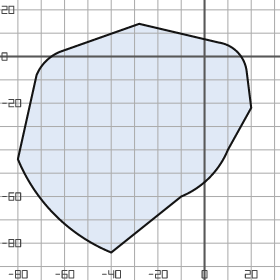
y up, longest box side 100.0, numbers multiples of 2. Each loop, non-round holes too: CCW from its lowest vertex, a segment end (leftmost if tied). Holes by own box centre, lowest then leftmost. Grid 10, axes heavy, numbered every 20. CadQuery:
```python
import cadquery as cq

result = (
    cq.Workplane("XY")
    .moveTo(-40.0, -84.0)
    .lineTo(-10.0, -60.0)
    .threePointArc((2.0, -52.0), (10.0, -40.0))
    .lineTo(20.0, -22.0)
    .lineTo(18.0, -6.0)
    .threePointArc((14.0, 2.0), (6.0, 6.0))
    .lineTo(-28.0, 14.0)
    .lineTo(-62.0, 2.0)
    .threePointArc((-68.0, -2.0), (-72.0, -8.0))
    .lineTo(-80.0, -44.0)
    .threePointArc((-64.0, -68.0), (-40.0, -84.0))
    .close()
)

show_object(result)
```